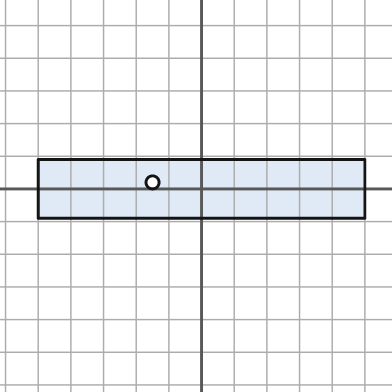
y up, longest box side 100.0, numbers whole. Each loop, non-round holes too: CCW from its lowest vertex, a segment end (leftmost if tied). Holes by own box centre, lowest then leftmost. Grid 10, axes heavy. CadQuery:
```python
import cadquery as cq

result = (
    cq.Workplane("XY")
    .moveTo(-50.0, -9.0)
    .lineTo(50.0, -9.0)
    .lineTo(50.0, 9.0)
    .lineTo(-50.0, 9.0)
    .close()
    .moveTo(-15.0, 2.0)
    .circle(2.0)
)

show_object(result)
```